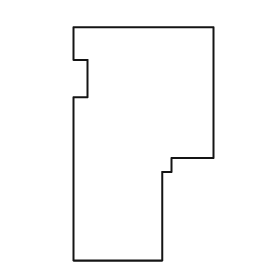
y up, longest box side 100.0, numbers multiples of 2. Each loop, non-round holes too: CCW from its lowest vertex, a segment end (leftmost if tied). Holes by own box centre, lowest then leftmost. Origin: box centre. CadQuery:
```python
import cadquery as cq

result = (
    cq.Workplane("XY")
    .moveTo(-30.0, -50.0)
    .lineTo(8.0, -50.0)
    .lineTo(8.0, -12.0)
    .lineTo(12.0, -12.0)
    .lineTo(12.0, -6.0)
    .lineTo(30.0, -6.0)
    .lineTo(30.0, 50.0)
    .lineTo(-30.0, 50.0)
    .lineTo(-30.0, 36.0)
    .lineTo(-24.0, 36.0)
    .lineTo(-24.0, 20.0)
    .lineTo(-30.0, 20.0)
    .close()
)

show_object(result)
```